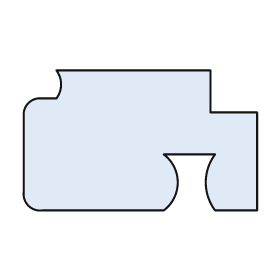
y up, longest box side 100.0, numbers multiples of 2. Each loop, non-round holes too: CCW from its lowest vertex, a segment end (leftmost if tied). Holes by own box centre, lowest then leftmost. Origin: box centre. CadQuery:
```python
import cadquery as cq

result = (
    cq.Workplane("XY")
    .moveTo(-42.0, -30.0)
    .lineTo(10.0, -30.0)
    .threePointArc((16.0, -18.0), (10.0, -6.0))
    .lineTo(32.0, -6.0)
    .threePointArc((28.0, -18.0), (32.0, -30.0))
    .lineTo(50.0, -30.0)
    .lineTo(50.0, 12.0)
    .lineTo(30.0, 12.0)
    .lineTo(30.0, 30.0)
    .lineTo(-36.0, 30.0)
    .threePointArc((-34.0, 24.0), (-36.0, 18.0))
    .lineTo(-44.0, 18.0)
    .threePointArc((-48.0, 16.0), (-50.0, 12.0))
    .lineTo(-50.0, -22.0)
    .threePointArc((-48.0, -28.0), (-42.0, -30.0))
    .close()
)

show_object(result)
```